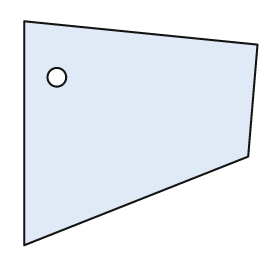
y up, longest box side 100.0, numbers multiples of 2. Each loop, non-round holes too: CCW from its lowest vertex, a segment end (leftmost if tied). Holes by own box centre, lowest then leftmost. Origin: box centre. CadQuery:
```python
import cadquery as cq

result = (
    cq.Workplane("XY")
    .moveTo(-50.0, -48.0)
    .lineTo(46.0, -10.0)
    .lineTo(50.0, 38.0)
    .lineTo(-50.0, 48.0)
    .close()
    .moveTo(-36.0, 24.0)
    .circle(4.0)
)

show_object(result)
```